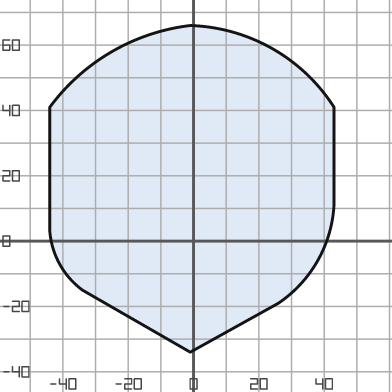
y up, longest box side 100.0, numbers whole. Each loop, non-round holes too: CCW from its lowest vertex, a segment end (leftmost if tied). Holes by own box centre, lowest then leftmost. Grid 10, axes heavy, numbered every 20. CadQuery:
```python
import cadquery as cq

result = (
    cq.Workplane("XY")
    .moveTo(-1.0, -34.0)
    .lineTo(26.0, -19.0)
    .threePointArc((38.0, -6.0), (43.0, 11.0))
    .lineTo(43.0, 41.0)
    .threePointArc((24.0, 59.0), (-1.0, 66.0))
    .threePointArc((-25.0, 58.0), (-44.0, 41.0))
    .lineTo(-44.0, 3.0)
    .threePointArc((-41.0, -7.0), (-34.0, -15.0))
    .close()
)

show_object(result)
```